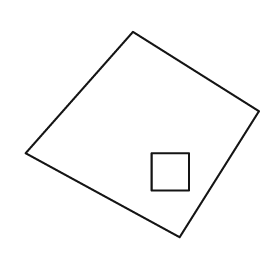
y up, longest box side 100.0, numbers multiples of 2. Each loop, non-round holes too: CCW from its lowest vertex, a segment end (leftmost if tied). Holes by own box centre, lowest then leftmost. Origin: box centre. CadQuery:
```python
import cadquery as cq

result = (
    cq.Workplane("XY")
    .moveTo(16.0, -44.0)
    .lineTo(50.0, 10.0)
    .lineTo(-4.0, 44.0)
    .lineTo(-50.0, -8.0)
    .close()
    .moveTo(4.0, -24.0)
    .lineTo(20.0, -24.0)
    .lineTo(20.0, -8.0)
    .lineTo(4.0, -8.0)
    .close()
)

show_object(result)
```